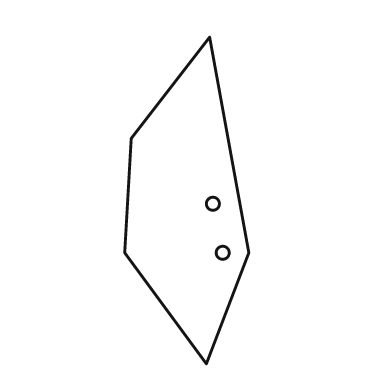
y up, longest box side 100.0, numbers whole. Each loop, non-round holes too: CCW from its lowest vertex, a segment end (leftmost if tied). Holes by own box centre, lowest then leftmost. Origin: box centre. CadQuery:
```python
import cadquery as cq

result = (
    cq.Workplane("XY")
    .moveTo(6.0, -50.0)
    .lineTo(19.0, -16.0)
    .lineTo(7.0, 50.0)
    .lineTo(-17.0, 19.0)
    .lineTo(-19.0, -16.0)
    .close()
    .moveTo(11.0, -16.0)
    .circle(2.0)
    .moveTo(8.0, -1.0)
    .circle(2.0)
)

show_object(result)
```